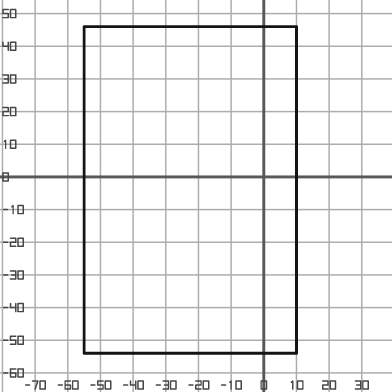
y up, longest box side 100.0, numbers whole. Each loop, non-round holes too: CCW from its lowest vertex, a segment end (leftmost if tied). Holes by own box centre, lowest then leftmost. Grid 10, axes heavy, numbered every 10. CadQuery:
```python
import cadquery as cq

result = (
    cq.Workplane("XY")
    .moveTo(-55.0, -54.0)
    .lineTo(10.0, -54.0)
    .lineTo(10.0, 46.0)
    .lineTo(-55.0, 46.0)
    .close()
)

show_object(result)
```